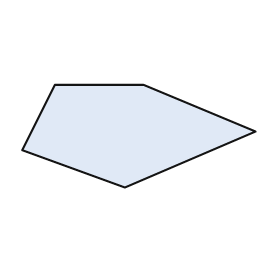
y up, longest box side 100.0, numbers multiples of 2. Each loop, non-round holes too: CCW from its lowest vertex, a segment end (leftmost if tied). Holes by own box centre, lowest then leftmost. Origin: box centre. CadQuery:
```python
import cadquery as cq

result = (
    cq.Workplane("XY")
    .moveTo(-6.0, -22.0)
    .lineTo(50.0, 2.0)
    .lineTo(2.0, 22.0)
    .lineTo(-36.0, 22.0)
    .lineTo(-50.0, -6.0)
    .close()
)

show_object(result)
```